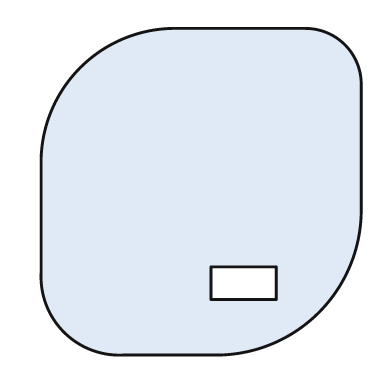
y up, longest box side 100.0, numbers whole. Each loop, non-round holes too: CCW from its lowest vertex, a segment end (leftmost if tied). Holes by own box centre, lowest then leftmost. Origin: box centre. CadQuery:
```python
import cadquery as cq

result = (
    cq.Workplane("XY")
    .moveTo(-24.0, -50.0)
    .lineTo(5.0, -50.0)
    .threePointArc((36.0, -37.0), (49.0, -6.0))
    .lineTo(49.0, 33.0)
    .threePointArc((44.0, 45.0), (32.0, 50.0))
    .lineTo(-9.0, 50.0)
    .threePointArc((-37.0, 38.0), (-49.0, 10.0))
    .lineTo(-49.0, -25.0)
    .threePointArc((-42.0, -43.0), (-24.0, -50.0))
    .close()
    .moveTo(3.0, -33.0)
    .lineTo(23.0, -33.0)
    .lineTo(23.0, -23.0)
    .lineTo(3.0, -23.0)
    .close()
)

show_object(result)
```